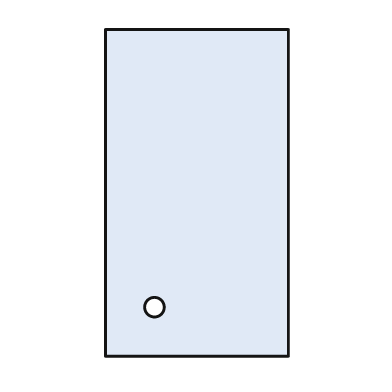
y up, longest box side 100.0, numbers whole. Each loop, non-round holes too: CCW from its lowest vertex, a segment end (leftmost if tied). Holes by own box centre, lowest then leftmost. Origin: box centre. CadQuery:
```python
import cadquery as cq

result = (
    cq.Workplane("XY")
    .moveTo(-28.0, -50.0)
    .lineTo(28.0, -50.0)
    .lineTo(28.0, 50.0)
    .lineTo(-28.0, 50.0)
    .close()
    .moveTo(-13.0, -35.0)
    .circle(3.0)
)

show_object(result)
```